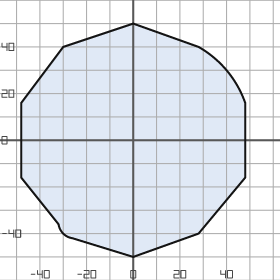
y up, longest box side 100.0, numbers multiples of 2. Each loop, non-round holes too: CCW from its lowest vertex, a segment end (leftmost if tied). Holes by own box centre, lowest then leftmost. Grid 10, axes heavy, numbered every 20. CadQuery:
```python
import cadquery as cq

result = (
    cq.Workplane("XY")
    .moveTo(0.0, -50.0)
    .lineTo(28.0, -40.0)
    .lineTo(48.0, -16.0)
    .lineTo(48.0, 16.0)
    .threePointArc((40.0, 30.0), (28.0, 40.0))
    .lineTo(0.0, 50.0)
    .lineTo(-30.0, 40.0)
    .lineTo(-48.0, 16.0)
    .lineTo(-48.0, -16.0)
    .lineTo(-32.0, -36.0)
    .threePointArc((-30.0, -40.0), (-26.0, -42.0))
    .close()
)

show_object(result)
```